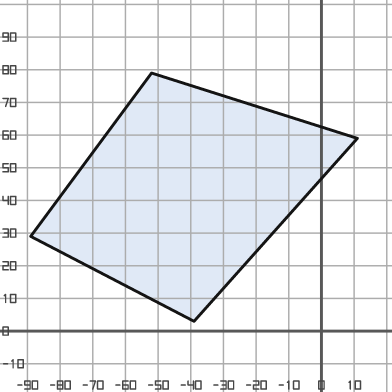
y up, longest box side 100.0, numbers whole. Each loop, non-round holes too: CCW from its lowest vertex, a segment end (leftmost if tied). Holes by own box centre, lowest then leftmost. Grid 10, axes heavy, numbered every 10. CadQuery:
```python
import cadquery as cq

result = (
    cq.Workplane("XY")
    .moveTo(-39.0, 3.0)
    .lineTo(11.0, 59.0)
    .lineTo(-52.0, 79.0)
    .lineTo(-89.0, 29.0)
    .close()
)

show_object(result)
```